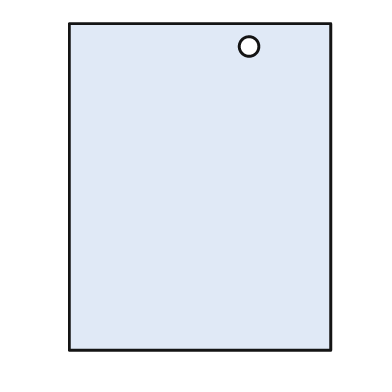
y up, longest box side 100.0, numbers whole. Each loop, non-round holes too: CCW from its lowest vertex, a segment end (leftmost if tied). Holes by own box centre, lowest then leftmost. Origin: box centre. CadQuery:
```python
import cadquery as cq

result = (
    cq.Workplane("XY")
    .moveTo(-40.0, -50.0)
    .lineTo(40.0, -50.0)
    .lineTo(40.0, 50.0)
    .lineTo(-40.0, 50.0)
    .close()
    .moveTo(15.0, 43.0)
    .circle(3.0)
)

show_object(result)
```